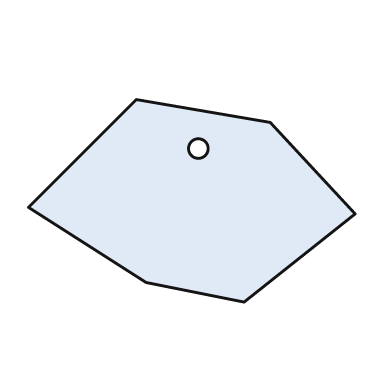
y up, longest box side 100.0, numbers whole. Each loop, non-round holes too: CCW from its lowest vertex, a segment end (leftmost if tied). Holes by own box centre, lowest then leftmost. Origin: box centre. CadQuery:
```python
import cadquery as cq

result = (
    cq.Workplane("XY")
    .moveTo(16.0, -31.0)
    .lineTo(50.0, -4.0)
    .lineTo(24.0, 24.0)
    .lineTo(-17.0, 31.0)
    .lineTo(-50.0, -2.0)
    .lineTo(-14.0, -25.0)
    .close()
    .moveTo(2.0, 16.0)
    .circle(3.0)
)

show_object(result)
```